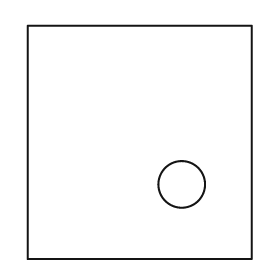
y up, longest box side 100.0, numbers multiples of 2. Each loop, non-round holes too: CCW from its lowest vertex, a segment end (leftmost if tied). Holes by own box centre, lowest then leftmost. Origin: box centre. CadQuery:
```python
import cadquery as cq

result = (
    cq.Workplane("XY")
    .moveTo(-48.0, -50.0)
    .lineTo(48.0, -50.0)
    .lineTo(48.0, 50.0)
    .lineTo(-48.0, 50.0)
    .close()
    .moveTo(18.0, -18.0)
    .circle(10.0)
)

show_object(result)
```